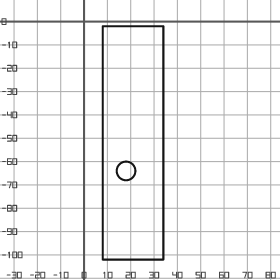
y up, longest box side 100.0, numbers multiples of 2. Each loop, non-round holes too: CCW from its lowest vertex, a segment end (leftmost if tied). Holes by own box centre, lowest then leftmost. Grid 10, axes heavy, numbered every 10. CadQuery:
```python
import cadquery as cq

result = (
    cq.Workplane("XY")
    .moveTo(8.0, -102.0)
    .lineTo(34.0, -102.0)
    .lineTo(34.0, -2.0)
    .lineTo(8.0, -2.0)
    .close()
    .moveTo(18.0, -64.0)
    .circle(4.0)
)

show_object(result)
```